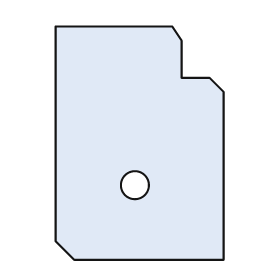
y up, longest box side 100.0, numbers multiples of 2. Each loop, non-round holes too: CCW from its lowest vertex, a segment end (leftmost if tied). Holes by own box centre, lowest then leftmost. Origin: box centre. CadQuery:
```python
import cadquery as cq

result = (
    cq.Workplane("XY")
    .moveTo(-28.0, -50.0)
    .lineTo(36.0, -50.0)
    .lineTo(36.0, 22.0)
    .lineTo(30.0, 28.0)
    .lineTo(18.0, 28.0)
    .lineTo(18.0, 44.0)
    .lineTo(14.0, 50.0)
    .lineTo(-36.0, 50.0)
    .lineTo(-36.0, -42.0)
    .close()
    .moveTo(-2.0, -18.0)
    .circle(6.0)
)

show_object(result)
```